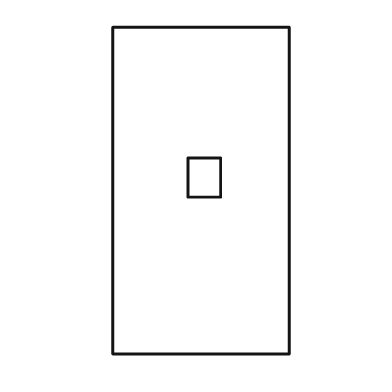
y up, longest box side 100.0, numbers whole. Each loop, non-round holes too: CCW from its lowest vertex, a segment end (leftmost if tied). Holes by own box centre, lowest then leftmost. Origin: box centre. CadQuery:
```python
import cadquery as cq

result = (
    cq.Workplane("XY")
    .moveTo(-27.0, -50.0)
    .lineTo(27.0, -50.0)
    .lineTo(27.0, 50.0)
    .lineTo(-27.0, 50.0)
    .close()
    .moveTo(-4.0, -2.0)
    .lineTo(6.0, -2.0)
    .lineTo(6.0, 10.0)
    .lineTo(-4.0, 10.0)
    .close()
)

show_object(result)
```